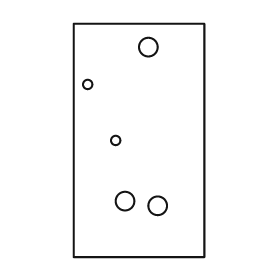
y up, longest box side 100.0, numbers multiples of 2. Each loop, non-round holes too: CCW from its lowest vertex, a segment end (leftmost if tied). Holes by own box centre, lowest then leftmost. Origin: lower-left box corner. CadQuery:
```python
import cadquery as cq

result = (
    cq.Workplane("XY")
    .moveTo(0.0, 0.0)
    .lineTo(56.0, 0.0)
    .lineTo(56.0, 100.0)
    .lineTo(0.0, 100.0)
    .close()
    .moveTo(36.0, 22.0)
    .circle(4.0)
    .moveTo(22.0, 24.0)
    .circle(4.0)
    .moveTo(18.0, 50.0)
    .circle(2.0)
    .moveTo(6.0, 74.0)
    .circle(2.0)
    .moveTo(32.0, 90.0)
    .circle(4.0)
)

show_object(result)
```